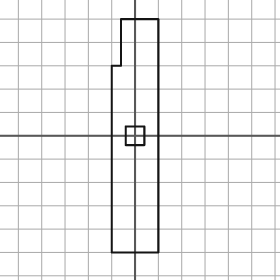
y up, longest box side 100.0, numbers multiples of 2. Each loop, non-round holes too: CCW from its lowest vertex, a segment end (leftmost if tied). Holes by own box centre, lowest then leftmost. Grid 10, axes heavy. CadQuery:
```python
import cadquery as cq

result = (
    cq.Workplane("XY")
    .moveTo(-10.0, -50.0)
    .lineTo(10.0, -50.0)
    .lineTo(10.0, 50.0)
    .lineTo(-6.0, 50.0)
    .lineTo(-6.0, 30.0)
    .lineTo(-10.0, 30.0)
    .close()
    .moveTo(-4.0, -4.0)
    .lineTo(4.0, -4.0)
    .lineTo(4.0, 4.0)
    .lineTo(-4.0, 4.0)
    .close()
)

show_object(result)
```